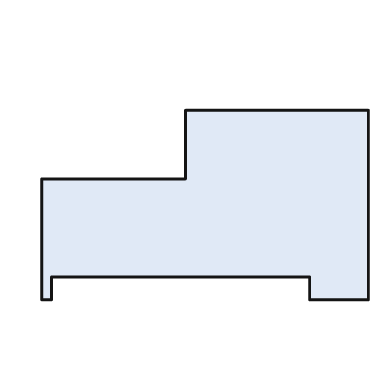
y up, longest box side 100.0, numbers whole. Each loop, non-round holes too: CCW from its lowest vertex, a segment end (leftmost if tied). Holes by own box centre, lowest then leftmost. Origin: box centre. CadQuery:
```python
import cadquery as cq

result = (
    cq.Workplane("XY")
    .moveTo(-50.0, -29.0)
    .lineTo(-47.0, -29.0)
    .lineTo(-47.0, -22.0)
    .lineTo(32.0, -22.0)
    .lineTo(32.0, -29.0)
    .lineTo(50.0, -29.0)
    .lineTo(50.0, 29.0)
    .lineTo(-6.0, 29.0)
    .lineTo(-6.0, 8.0)
    .lineTo(-50.0, 8.0)
    .close()
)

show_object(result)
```